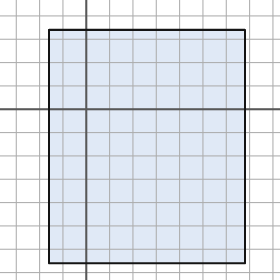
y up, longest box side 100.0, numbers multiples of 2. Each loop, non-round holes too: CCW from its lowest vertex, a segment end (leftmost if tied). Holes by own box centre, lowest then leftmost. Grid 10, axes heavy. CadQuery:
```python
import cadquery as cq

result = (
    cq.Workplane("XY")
    .moveTo(-16.0, -66.0)
    .lineTo(68.0, -66.0)
    .lineTo(68.0, 34.0)
    .lineTo(-16.0, 34.0)
    .close()
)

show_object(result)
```